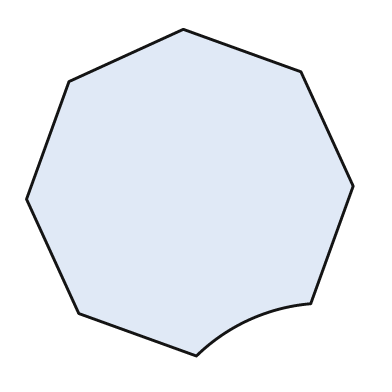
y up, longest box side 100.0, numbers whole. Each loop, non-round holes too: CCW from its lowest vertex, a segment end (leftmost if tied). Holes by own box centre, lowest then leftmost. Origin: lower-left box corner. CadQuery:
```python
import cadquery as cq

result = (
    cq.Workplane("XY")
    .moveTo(52.0, 0.0)
    .threePointArc((68.0, 11.0), (87.0, 16.0))
    .lineTo(100.0, 52.0)
    .lineTo(84.0, 87.0)
    .lineTo(48.0, 100.0)
    .lineTo(13.0, 84.0)
    .lineTo(0.0, 48.0)
    .lineTo(16.0, 13.0)
    .close()
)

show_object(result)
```